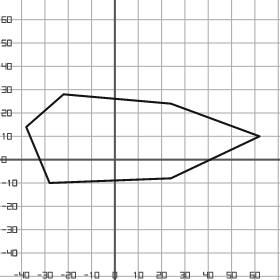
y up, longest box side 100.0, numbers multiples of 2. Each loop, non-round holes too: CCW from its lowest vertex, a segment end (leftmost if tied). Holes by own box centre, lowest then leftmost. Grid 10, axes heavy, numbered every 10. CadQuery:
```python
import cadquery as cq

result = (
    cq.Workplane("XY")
    .moveTo(-28.0, -10.0)
    .lineTo(24.0, -8.0)
    .lineTo(62.0, 10.0)
    .lineTo(24.0, 24.0)
    .lineTo(-22.0, 28.0)
    .lineTo(-38.0, 14.0)
    .close()
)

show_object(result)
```